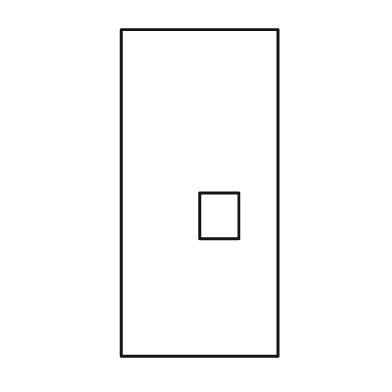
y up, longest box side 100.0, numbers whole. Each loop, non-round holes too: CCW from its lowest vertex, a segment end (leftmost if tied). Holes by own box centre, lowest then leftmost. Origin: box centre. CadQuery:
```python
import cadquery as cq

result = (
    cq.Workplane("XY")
    .moveTo(-24.0, -50.0)
    .lineTo(24.0, -50.0)
    .lineTo(24.0, 50.0)
    .lineTo(-24.0, 50.0)
    .close()
    .moveTo(0.0, -14.0)
    .lineTo(12.0, -14.0)
    .lineTo(12.0, 0.0)
    .lineTo(0.0, 0.0)
    .close()
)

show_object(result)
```